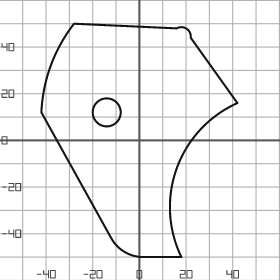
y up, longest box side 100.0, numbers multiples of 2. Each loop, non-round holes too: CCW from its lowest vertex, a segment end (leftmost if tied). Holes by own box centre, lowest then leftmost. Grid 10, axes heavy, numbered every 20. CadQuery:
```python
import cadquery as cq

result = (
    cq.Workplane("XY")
    .moveTo(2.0, -50.0)
    .lineTo(18.0, -50.0)
    .threePointArc((16.0, -12.0), (42.0, 16.0))
    .lineTo(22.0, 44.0)
    .threePointArc((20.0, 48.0), (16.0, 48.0))
    .lineTo(-28.0, 50.0)
    .threePointArc((-38.0, 32.0), (-42.0, 12.0))
    .lineTo(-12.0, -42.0)
    .threePointArc((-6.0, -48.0), (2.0, -50.0))
    .close()
    .moveTo(-14.0, 12.0)
    .circle(6.0)
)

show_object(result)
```